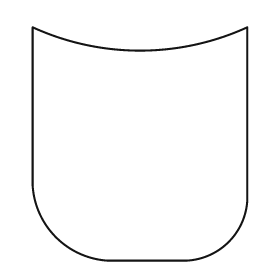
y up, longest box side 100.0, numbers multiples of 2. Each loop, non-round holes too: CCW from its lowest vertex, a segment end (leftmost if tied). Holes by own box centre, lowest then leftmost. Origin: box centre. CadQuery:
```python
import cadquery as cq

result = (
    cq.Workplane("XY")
    .moveTo(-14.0, -50.0)
    .lineTo(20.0, -50.0)
    .threePointArc((38.0, -42.0), (46.0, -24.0))
    .lineTo(46.0, 50.0)
    .threePointArc((0.0, 40.0), (-46.0, 50.0))
    .lineTo(-46.0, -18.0)
    .threePointArc((-36.0, -40.0), (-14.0, -50.0))
    .close()
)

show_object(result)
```